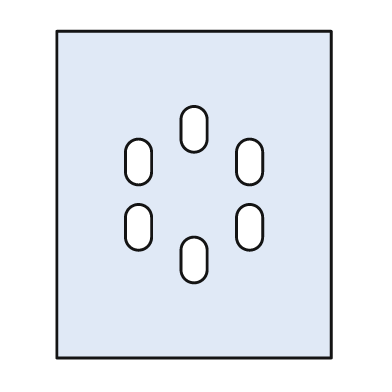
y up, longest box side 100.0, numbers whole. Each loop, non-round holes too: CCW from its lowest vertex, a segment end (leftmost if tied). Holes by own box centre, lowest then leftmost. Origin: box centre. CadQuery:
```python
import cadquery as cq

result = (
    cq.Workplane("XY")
    .moveTo(-42.0, -50.0)
    .lineTo(42.0, -50.0)
    .lineTo(42.0, 50.0)
    .lineTo(-42.0, 50.0)
    .close()
    .moveTo(-4.0, -23.0)
    .threePointArc((0.0, -27.0), (4.0, -23.0))
    .lineTo(4.0, -17.0)
    .threePointArc((0.0, -13.0), (-4.0, -17.0))
    .close()
    .moveTo(-21.0, -13.0)
    .threePointArc((-17.0, -17.0), (-13.0, -13.0))
    .lineTo(-13.0, -7.0)
    .threePointArc((-17.0, -3.0), (-21.0, -7.0))
    .close()
    .moveTo(13.0, -13.0)
    .threePointArc((17.0, -17.0), (21.0, -13.0))
    .lineTo(21.0, -7.0)
    .threePointArc((17.0, -3.0), (13.0, -7.0))
    .close()
    .moveTo(-21.0, 7.0)
    .threePointArc((-17.0, 3.0), (-13.0, 7.0))
    .lineTo(-13.0, 13.0)
    .threePointArc((-17.0, 17.0), (-21.0, 13.0))
    .close()
    .moveTo(13.0, 7.0)
    .threePointArc((17.0, 3.0), (21.0, 7.0))
    .lineTo(21.0, 13.0)
    .threePointArc((17.0, 17.0), (13.0, 13.0))
    .close()
    .moveTo(-4.0, 17.0)
    .threePointArc((0.0, 13.0), (4.0, 17.0))
    .lineTo(4.0, 23.0)
    .threePointArc((0.0, 27.0), (-4.0, 23.0))
    .close()
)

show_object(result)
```